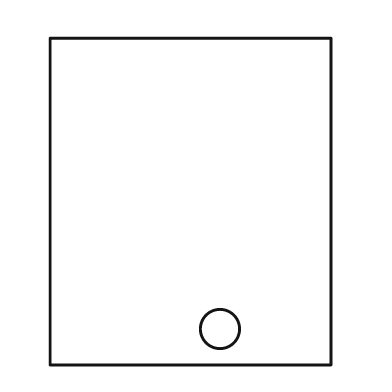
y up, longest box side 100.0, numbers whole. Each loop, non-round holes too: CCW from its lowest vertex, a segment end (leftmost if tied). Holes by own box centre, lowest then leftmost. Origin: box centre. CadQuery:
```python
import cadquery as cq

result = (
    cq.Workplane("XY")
    .moveTo(-43.0, -50.0)
    .lineTo(43.0, -50.0)
    .lineTo(43.0, 50.0)
    .lineTo(-43.0, 50.0)
    .close()
    .moveTo(9.0, -39.0)
    .circle(6.0)
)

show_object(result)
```